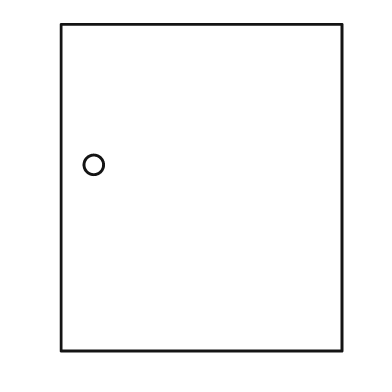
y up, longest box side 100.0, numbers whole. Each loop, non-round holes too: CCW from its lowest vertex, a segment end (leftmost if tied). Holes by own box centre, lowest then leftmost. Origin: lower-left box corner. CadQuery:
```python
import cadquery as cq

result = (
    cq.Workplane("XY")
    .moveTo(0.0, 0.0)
    .lineTo(86.0, 0.0)
    .lineTo(86.0, 100.0)
    .lineTo(0.0, 100.0)
    .close()
    .moveTo(10.0, 57.0)
    .circle(3.0)
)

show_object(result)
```